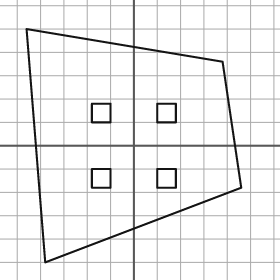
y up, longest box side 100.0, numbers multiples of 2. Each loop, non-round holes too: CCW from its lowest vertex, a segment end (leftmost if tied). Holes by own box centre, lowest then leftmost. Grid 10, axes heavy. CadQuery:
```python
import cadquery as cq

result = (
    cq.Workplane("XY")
    .moveTo(-38.0, -50.0)
    .lineTo(46.0, -18.0)
    .lineTo(38.0, 36.0)
    .lineTo(-46.0, 50.0)
    .close()
    .moveTo(-18.0, -18.0)
    .lineTo(-10.0, -18.0)
    .lineTo(-10.0, -10.0)
    .lineTo(-18.0, -10.0)
    .close()
    .moveTo(10.0, -18.0)
    .lineTo(18.0, -18.0)
    .lineTo(18.0, -10.0)
    .lineTo(10.0, -10.0)
    .close()
    .moveTo(-18.0, 10.0)
    .lineTo(-10.0, 10.0)
    .lineTo(-10.0, 18.0)
    .lineTo(-18.0, 18.0)
    .close()
    .moveTo(10.0, 10.0)
    .lineTo(18.0, 10.0)
    .lineTo(18.0, 18.0)
    .lineTo(10.0, 18.0)
    .close()
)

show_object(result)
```